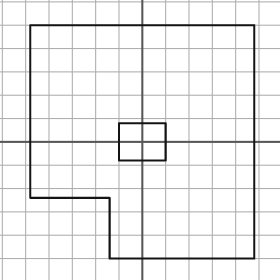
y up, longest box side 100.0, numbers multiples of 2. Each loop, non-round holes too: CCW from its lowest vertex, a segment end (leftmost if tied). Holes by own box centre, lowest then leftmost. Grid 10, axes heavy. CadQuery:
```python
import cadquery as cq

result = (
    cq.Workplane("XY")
    .moveTo(-14.0, -50.0)
    .lineTo(48.0, -50.0)
    .lineTo(48.0, 50.0)
    .lineTo(-48.0, 50.0)
    .lineTo(-48.0, -24.0)
    .lineTo(-14.0, -24.0)
    .close()
    .moveTo(-10.0, -8.0)
    .lineTo(10.0, -8.0)
    .lineTo(10.0, 8.0)
    .lineTo(-10.0, 8.0)
    .close()
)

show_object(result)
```